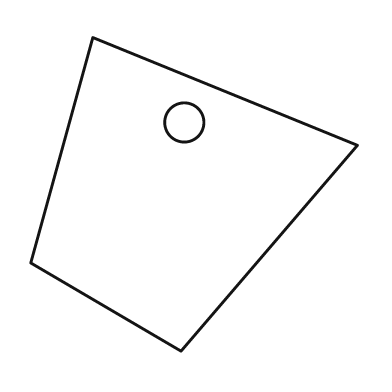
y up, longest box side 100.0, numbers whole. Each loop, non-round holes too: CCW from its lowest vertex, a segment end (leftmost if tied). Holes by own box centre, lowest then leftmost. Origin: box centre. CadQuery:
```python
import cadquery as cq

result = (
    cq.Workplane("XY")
    .moveTo(-4.0, -48.0)
    .lineTo(50.0, 15.0)
    .lineTo(-31.0, 48.0)
    .lineTo(-50.0, -21.0)
    .close()
    .moveTo(-3.0, 22.0)
    .circle(6.0)
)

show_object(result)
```